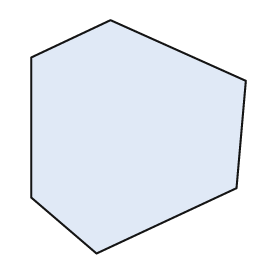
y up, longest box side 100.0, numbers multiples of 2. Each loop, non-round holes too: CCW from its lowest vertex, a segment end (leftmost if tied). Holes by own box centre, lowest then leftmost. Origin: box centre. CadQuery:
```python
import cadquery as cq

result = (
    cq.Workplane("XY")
    .moveTo(-18.0, -50.0)
    .lineTo(42.0, -22.0)
    .lineTo(46.0, 24.0)
    .lineTo(-12.0, 50.0)
    .lineTo(-46.0, 34.0)
    .lineTo(-46.0, -26.0)
    .close()
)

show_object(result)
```